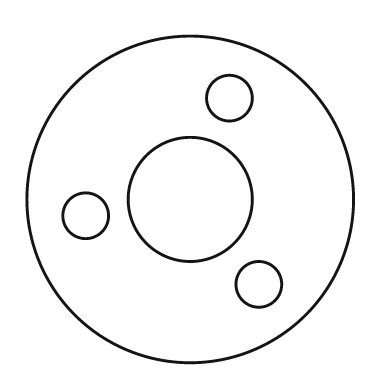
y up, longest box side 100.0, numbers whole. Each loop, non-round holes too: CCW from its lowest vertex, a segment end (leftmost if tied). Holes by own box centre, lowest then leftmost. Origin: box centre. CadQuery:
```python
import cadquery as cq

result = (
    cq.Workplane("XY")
    .moveTo(0.0, 0.0)
    .circle(50.0)
    .moveTo(21.0, -26.0)
    .circle(7.0)
    .moveTo(-32.0, -5.0)
    .circle(7.0)
    .moveTo(0.0, 0.0)
    .circle(19.0)
    .moveTo(12.0, 31.0)
    .circle(7.0)
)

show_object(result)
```